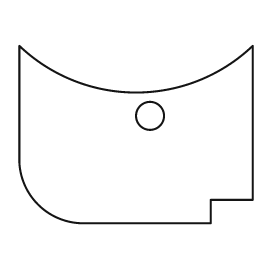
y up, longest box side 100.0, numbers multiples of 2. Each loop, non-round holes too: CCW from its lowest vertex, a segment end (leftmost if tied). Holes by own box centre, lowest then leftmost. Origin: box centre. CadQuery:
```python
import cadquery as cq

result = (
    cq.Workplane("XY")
    .moveTo(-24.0, -38.0)
    .lineTo(32.0, -38.0)
    .lineTo(32.0, -28.0)
    .lineTo(50.0, -28.0)
    .lineTo(50.0, 38.0)
    .threePointArc((0.0, 18.0), (-50.0, 38.0))
    .lineTo(-50.0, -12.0)
    .threePointArc((-42.0, -30.0), (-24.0, -38.0))
    .close()
    .moveTo(6.0, 8.0)
    .circle(6.0)
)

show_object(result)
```